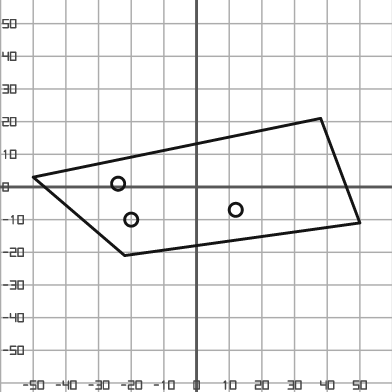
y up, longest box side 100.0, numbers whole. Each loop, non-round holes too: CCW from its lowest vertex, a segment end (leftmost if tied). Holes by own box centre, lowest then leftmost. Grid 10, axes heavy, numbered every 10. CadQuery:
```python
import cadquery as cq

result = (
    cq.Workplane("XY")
    .moveTo(-22.0, -21.0)
    .lineTo(50.0, -11.0)
    .lineTo(38.0, 21.0)
    .lineTo(-50.0, 3.0)
    .close()
    .moveTo(-20.0, -10.0)
    .circle(2.0)
    .moveTo(12.0, -7.0)
    .circle(2.0)
    .moveTo(-24.0, 1.0)
    .circle(2.0)
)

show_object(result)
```